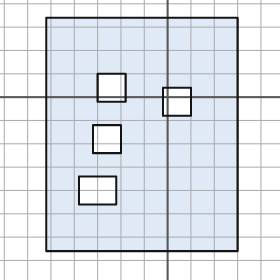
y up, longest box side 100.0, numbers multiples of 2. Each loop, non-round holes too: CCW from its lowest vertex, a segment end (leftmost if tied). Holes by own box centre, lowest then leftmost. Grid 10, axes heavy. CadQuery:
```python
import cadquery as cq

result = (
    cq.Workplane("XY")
    .moveTo(-52.0, -66.0)
    .lineTo(30.0, -66.0)
    .lineTo(30.0, 34.0)
    .lineTo(-52.0, 34.0)
    .close()
    .moveTo(-38.0, -46.0)
    .lineTo(-22.0, -46.0)
    .lineTo(-22.0, -34.0)
    .lineTo(-38.0, -34.0)
    .close()
    .moveTo(-32.0, -24.0)
    .lineTo(-20.0, -24.0)
    .lineTo(-20.0, -12.0)
    .lineTo(-32.0, -12.0)
    .close()
    .moveTo(-2.0, -8.0)
    .lineTo(10.0, -8.0)
    .lineTo(10.0, 4.0)
    .lineTo(-2.0, 4.0)
    .close()
    .moveTo(-30.0, -2.0)
    .lineTo(-18.0, -2.0)
    .lineTo(-18.0, 10.0)
    .lineTo(-30.0, 10.0)
    .close()
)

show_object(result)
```